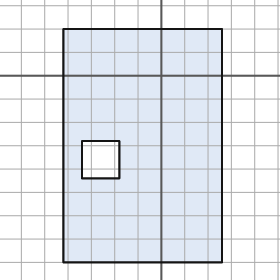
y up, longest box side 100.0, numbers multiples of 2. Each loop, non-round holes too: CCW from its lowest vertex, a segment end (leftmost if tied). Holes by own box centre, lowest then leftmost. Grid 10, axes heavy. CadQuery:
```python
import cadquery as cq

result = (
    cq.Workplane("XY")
    .moveTo(-42.0, -80.0)
    .lineTo(26.0, -80.0)
    .lineTo(26.0, 20.0)
    .lineTo(-42.0, 20.0)
    .close()
    .moveTo(-34.0, -44.0)
    .lineTo(-18.0, -44.0)
    .lineTo(-18.0, -28.0)
    .lineTo(-34.0, -28.0)
    .close()
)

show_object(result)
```